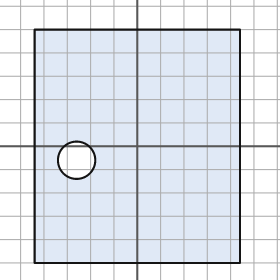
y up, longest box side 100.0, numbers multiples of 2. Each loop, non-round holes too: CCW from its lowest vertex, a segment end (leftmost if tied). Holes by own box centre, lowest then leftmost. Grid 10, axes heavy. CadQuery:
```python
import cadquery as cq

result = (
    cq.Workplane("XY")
    .moveTo(-44.0, -50.0)
    .lineTo(44.0, -50.0)
    .lineTo(44.0, 50.0)
    .lineTo(-44.0, 50.0)
    .close()
    .moveTo(-26.0, -6.0)
    .circle(8.0)
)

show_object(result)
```